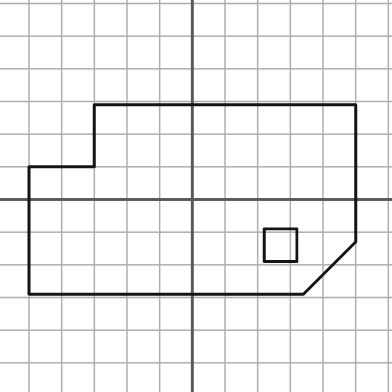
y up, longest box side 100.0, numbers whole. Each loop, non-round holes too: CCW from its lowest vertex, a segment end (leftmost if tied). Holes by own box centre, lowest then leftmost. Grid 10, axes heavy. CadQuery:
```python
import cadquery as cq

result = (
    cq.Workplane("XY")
    .moveTo(-50.0, -29.0)
    .lineTo(34.0, -29.0)
    .lineTo(50.0, -13.0)
    .lineTo(50.0, 29.0)
    .lineTo(-30.0, 29.0)
    .lineTo(-30.0, 10.0)
    .lineTo(-50.0, 10.0)
    .close()
    .moveTo(22.0, -19.0)
    .lineTo(32.0, -19.0)
    .lineTo(32.0, -9.0)
    .lineTo(22.0, -9.0)
    .close()
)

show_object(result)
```